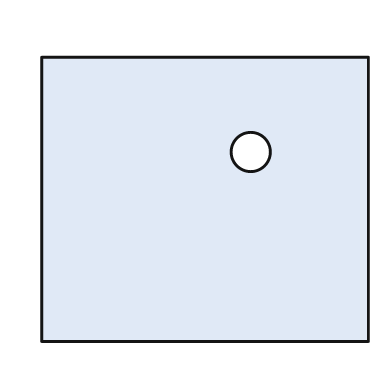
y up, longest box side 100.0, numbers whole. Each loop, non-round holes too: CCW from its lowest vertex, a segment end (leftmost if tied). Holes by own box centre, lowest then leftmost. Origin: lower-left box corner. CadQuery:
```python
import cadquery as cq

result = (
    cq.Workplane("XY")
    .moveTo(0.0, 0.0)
    .lineTo(100.0, 0.0)
    .lineTo(100.0, 87.0)
    .lineTo(0.0, 87.0)
    .close()
    .moveTo(64.0, 58.0)
    .circle(6.0)
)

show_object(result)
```